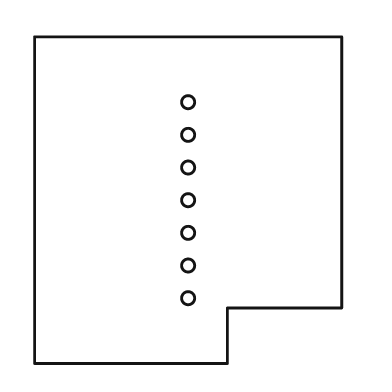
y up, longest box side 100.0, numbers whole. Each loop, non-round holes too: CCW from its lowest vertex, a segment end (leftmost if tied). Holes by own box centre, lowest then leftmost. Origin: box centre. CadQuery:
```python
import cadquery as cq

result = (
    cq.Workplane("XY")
    .moveTo(-47.0, -50.0)
    .lineTo(12.0, -50.0)
    .lineTo(12.0, -33.0)
    .lineTo(47.0, -33.0)
    .lineTo(47.0, 50.0)
    .lineTo(-47.0, 50.0)
    .close()
    .moveTo(0.0, -30.0)
    .circle(2.0)
    .moveTo(0.0, -20.0)
    .circle(2.0)
    .moveTo(0.0, -10.0)
    .circle(2.0)
    .moveTo(0.0, 0.0)
    .circle(2.0)
    .moveTo(0.0, 10.0)
    .circle(2.0)
    .moveTo(0.0, 20.0)
    .circle(2.0)
    .moveTo(0.0, 30.0)
    .circle(2.0)
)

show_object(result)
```